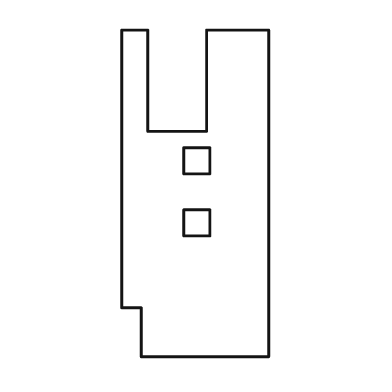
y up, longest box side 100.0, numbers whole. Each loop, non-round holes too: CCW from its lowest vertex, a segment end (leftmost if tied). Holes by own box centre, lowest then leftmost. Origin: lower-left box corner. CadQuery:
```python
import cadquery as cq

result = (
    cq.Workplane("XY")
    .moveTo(6.0, 0.0)
    .lineTo(45.0, 0.0)
    .lineTo(45.0, 100.0)
    .lineTo(26.0, 100.0)
    .lineTo(26.0, 69.0)
    .lineTo(8.0, 69.0)
    .lineTo(8.0, 100.0)
    .lineTo(0.0, 100.0)
    .lineTo(0.0, 15.0)
    .lineTo(6.0, 15.0)
    .close()
    .moveTo(19.0, 37.0)
    .lineTo(27.0, 37.0)
    .lineTo(27.0, 45.0)
    .lineTo(19.0, 45.0)
    .close()
    .moveTo(19.0, 56.0)
    .lineTo(27.0, 56.0)
    .lineTo(27.0, 64.0)
    .lineTo(19.0, 64.0)
    .close()
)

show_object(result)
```